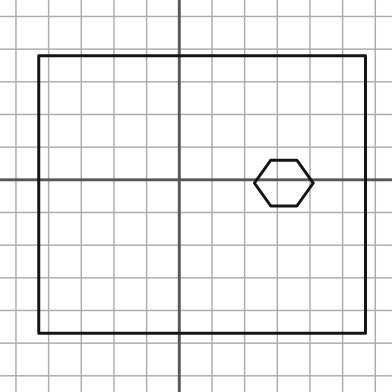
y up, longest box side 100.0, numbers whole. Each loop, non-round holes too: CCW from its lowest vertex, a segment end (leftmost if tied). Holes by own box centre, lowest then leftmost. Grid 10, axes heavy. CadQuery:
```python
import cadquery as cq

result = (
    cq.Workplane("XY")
    .moveTo(-43.0, -47.0)
    .lineTo(57.0, -47.0)
    .lineTo(57.0, 38.0)
    .lineTo(-43.0, 38.0)
    .close()
    .moveTo(28.0, -8.0)
    .lineTo(36.0, -8.0)
    .lineTo(41.0, -1.0)
    .lineTo(36.0, 6.0)
    .lineTo(28.0, 6.0)
    .lineTo(23.0, -1.0)
    .close()
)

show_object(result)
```